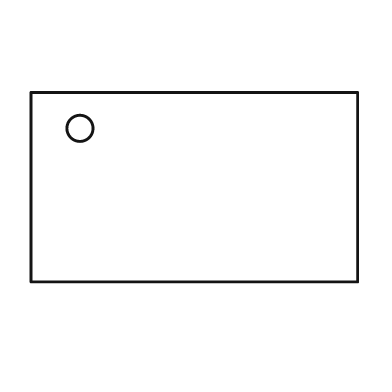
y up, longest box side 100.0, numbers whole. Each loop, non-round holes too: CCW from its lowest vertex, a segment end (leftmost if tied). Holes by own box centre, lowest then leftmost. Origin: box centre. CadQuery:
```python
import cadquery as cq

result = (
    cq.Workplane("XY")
    .moveTo(-50.0, -29.0)
    .lineTo(50.0, -29.0)
    .lineTo(50.0, 29.0)
    .lineTo(-50.0, 29.0)
    .close()
    .moveTo(-35.0, 18.0)
    .circle(4.0)
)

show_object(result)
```